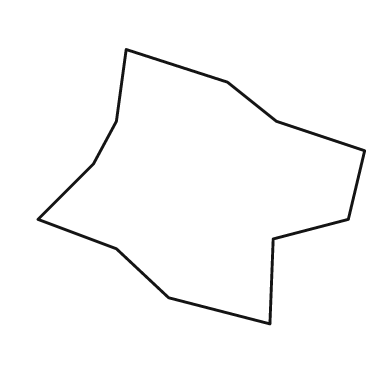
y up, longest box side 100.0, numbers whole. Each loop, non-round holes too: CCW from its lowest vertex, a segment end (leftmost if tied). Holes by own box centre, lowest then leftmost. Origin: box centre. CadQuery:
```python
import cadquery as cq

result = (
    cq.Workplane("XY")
    .moveTo(21.0, -42.0)
    .lineTo(22.0, -16.0)
    .lineTo(45.0, -10.0)
    .lineTo(50.0, 11.0)
    .lineTo(23.0, 20.0)
    .lineTo(8.0, 32.0)
    .lineTo(-23.0, 42.0)
    .lineTo(-26.0, 20.0)
    .lineTo(-33.0, 7.0)
    .lineTo(-50.0, -10.0)
    .lineTo(-26.0, -19.0)
    .lineTo(-10.0, -34.0)
    .close()
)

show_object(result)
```